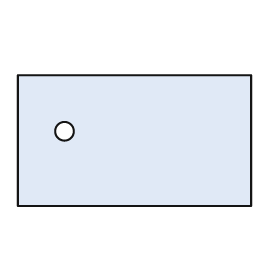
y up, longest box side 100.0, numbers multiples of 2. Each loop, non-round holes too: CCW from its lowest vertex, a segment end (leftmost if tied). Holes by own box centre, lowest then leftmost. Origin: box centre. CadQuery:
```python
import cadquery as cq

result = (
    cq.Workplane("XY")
    .moveTo(-50.0, -28.0)
    .lineTo(50.0, -28.0)
    .lineTo(50.0, 28.0)
    .lineTo(-50.0, 28.0)
    .close()
    .moveTo(-30.0, 4.0)
    .circle(4.0)
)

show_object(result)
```